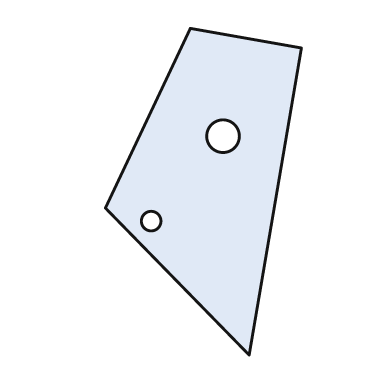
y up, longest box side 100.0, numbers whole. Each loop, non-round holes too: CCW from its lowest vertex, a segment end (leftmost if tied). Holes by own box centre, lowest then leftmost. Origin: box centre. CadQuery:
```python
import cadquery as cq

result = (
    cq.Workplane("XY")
    .moveTo(14.0, -50.0)
    .lineTo(30.0, 44.0)
    .lineTo(-4.0, 50.0)
    .lineTo(-30.0, -5.0)
    .close()
    .moveTo(-16.0, -9.0)
    .circle(3.0)
    .moveTo(6.0, 17.0)
    .circle(5.0)
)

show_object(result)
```